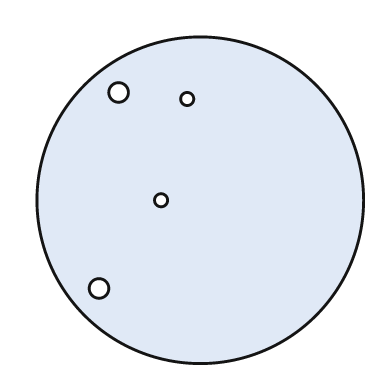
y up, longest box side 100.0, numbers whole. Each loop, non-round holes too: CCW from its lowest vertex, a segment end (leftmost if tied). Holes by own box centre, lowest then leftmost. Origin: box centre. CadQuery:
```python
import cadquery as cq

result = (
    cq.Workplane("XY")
    .moveTo(0.0, 0.0)
    .circle(50.0)
    .moveTo(-31.0, -27.0)
    .circle(3.0)
    .moveTo(-12.0, 0.0)
    .circle(2.0)
    .moveTo(-4.0, 31.0)
    .circle(2.0)
    .moveTo(-25.0, 33.0)
    .circle(3.0)
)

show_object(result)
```